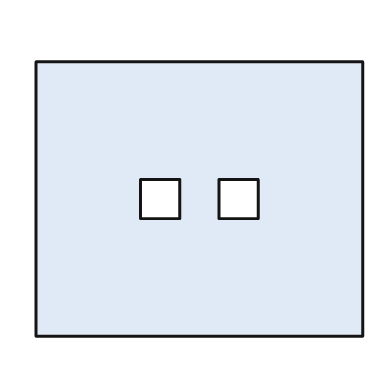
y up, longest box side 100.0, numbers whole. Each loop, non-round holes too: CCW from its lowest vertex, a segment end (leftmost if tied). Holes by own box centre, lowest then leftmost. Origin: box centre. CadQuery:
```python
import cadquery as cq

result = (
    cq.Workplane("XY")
    .moveTo(-50.0, -42.0)
    .lineTo(50.0, -42.0)
    .lineTo(50.0, 42.0)
    .lineTo(-50.0, 42.0)
    .close()
    .moveTo(-18.0, -6.0)
    .lineTo(-6.0, -6.0)
    .lineTo(-6.0, 6.0)
    .lineTo(-18.0, 6.0)
    .close()
    .moveTo(6.0, -6.0)
    .lineTo(18.0, -6.0)
    .lineTo(18.0, 6.0)
    .lineTo(6.0, 6.0)
    .close()
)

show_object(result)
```